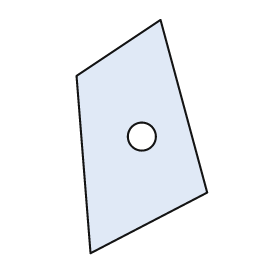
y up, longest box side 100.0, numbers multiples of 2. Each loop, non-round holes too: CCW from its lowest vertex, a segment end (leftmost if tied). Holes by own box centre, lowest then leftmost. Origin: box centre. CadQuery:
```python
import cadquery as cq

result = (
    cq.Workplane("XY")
    .moveTo(-22.0, -50.0)
    .lineTo(28.0, -24.0)
    .lineTo(8.0, 50.0)
    .lineTo(-28.0, 26.0)
    .close()
    .moveTo(0.0, 0.0)
    .circle(6.0)
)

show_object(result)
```